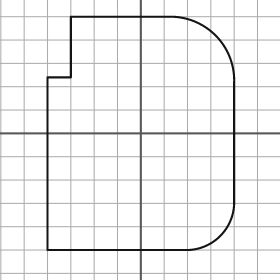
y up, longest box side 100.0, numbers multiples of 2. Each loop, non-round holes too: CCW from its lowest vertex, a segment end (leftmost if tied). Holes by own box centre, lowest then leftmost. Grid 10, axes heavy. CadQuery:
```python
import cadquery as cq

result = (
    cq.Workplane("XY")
    .moveTo(-40.0, -50.0)
    .lineTo(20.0, -50.0)
    .threePointArc((34.0, -44.0), (40.0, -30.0))
    .lineTo(40.0, 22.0)
    .threePointArc((32.0, 42.0), (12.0, 50.0))
    .lineTo(-30.0, 50.0)
    .lineTo(-30.0, 24.0)
    .lineTo(-40.0, 24.0)
    .close()
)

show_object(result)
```